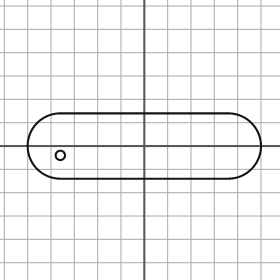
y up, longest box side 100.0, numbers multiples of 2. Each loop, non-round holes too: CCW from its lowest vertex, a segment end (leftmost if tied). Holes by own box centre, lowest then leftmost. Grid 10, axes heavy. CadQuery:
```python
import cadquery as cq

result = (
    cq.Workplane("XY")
    .moveTo(-36.0, -14.0)
    .lineTo(36.0, -14.0)
    .threePointArc((50.0, 0.0), (36.0, 14.0))
    .lineTo(-36.0, 14.0)
    .threePointArc((-50.0, 0.0), (-36.0, -14.0))
    .close()
    .moveTo(-36.0, -4.0)
    .circle(2.0)
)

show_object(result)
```